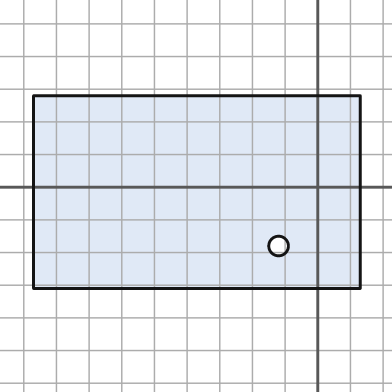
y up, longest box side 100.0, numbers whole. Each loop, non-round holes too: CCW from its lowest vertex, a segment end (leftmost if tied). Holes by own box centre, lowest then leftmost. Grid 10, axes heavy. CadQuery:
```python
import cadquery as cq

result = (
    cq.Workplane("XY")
    .moveTo(-87.0, -31.0)
    .lineTo(13.0, -31.0)
    .lineTo(13.0, 28.0)
    .lineTo(-87.0, 28.0)
    .close()
    .moveTo(-12.0, -18.0)
    .circle(3.0)
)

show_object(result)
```